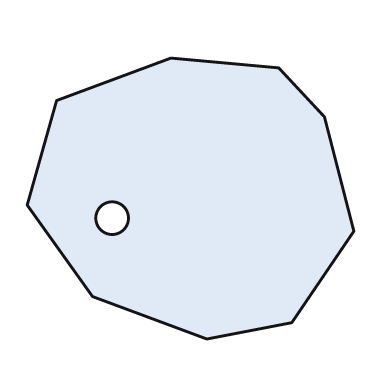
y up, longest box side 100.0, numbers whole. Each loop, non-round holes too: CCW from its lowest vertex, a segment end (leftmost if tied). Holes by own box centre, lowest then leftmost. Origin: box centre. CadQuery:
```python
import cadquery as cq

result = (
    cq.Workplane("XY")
    .moveTo(5.0, -43.0)
    .lineTo(31.0, -38.0)
    .lineTo(50.0, -10.0)
    .lineTo(41.0, 25.0)
    .lineTo(27.0, 40.0)
    .lineTo(-6.0, 43.0)
    .lineTo(-41.0, 30.0)
    .lineTo(-50.0, -2.0)
    .lineTo(-30.0, -30.0)
    .close()
    .moveTo(-24.0, -6.0)
    .circle(5.0)
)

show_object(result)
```